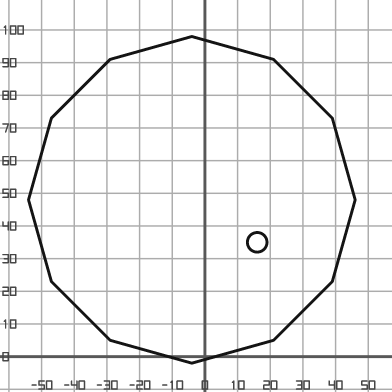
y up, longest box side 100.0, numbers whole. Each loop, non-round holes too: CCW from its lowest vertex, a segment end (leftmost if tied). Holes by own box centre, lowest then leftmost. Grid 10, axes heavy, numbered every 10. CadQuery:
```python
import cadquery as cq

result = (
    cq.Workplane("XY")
    .moveTo(-4.0, -2.0)
    .lineTo(21.0, 5.0)
    .lineTo(39.0, 23.0)
    .lineTo(46.0, 48.0)
    .lineTo(39.0, 73.0)
    .lineTo(21.0, 91.0)
    .lineTo(-4.0, 98.0)
    .lineTo(-29.0, 91.0)
    .lineTo(-47.0, 73.0)
    .lineTo(-54.0, 48.0)
    .lineTo(-47.0, 23.0)
    .lineTo(-29.0, 5.0)
    .close()
    .moveTo(16.0, 35.0)
    .circle(3.0)
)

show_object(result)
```